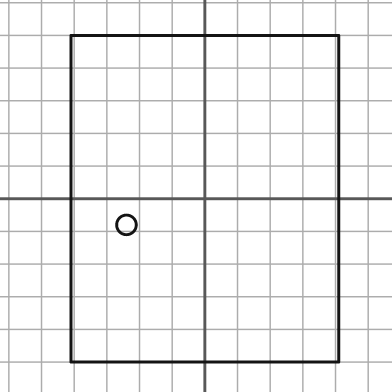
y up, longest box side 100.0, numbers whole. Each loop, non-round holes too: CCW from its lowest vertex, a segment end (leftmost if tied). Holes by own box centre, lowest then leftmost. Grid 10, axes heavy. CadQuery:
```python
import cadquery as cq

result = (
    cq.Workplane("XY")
    .moveTo(-41.0, -50.0)
    .lineTo(41.0, -50.0)
    .lineTo(41.0, 50.0)
    .lineTo(-41.0, 50.0)
    .close()
    .moveTo(-24.0, -8.0)
    .circle(3.0)
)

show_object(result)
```